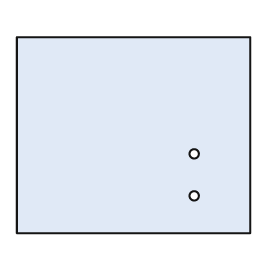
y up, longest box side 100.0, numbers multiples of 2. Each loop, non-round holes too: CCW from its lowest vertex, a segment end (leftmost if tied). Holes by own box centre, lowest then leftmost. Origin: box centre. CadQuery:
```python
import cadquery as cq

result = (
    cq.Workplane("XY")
    .moveTo(-50.0, -42.0)
    .lineTo(50.0, -42.0)
    .lineTo(50.0, 42.0)
    .lineTo(-50.0, 42.0)
    .close()
    .moveTo(26.0, -26.0)
    .circle(2.0)
    .moveTo(26.0, -8.0)
    .circle(2.0)
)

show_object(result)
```